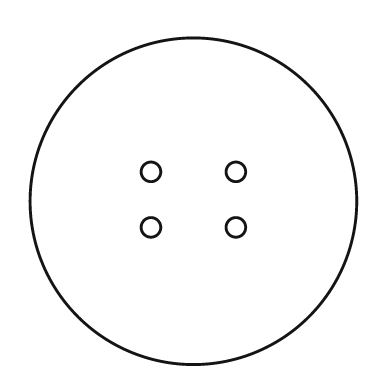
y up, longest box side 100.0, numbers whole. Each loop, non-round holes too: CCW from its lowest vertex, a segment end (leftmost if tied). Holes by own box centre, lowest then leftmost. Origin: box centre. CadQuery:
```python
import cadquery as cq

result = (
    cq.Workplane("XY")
    .moveTo(0.0, 0.0)
    .circle(50.0)
    .moveTo(-13.0, -8.0)
    .circle(3.0)
    .moveTo(13.0, -8.0)
    .circle(3.0)
    .moveTo(-13.0, 9.0)
    .circle(3.0)
    .moveTo(13.0, 9.0)
    .circle(3.0)
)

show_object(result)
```